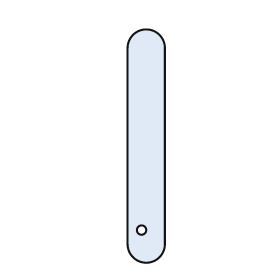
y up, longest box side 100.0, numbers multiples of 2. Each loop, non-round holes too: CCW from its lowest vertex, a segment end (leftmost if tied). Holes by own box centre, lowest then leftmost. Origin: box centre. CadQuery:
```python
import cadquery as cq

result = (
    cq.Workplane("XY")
    .moveTo(-8.0, -42.0)
    .threePointArc((0.0, -50.0), (8.0, -42.0))
    .lineTo(8.0, 42.0)
    .threePointArc((0.0, 50.0), (-8.0, 42.0))
    .close()
    .moveTo(-2.0, -36.0)
    .circle(2.0)
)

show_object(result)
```